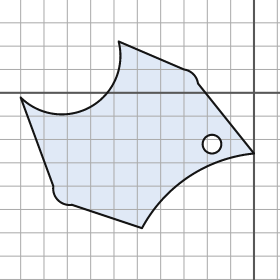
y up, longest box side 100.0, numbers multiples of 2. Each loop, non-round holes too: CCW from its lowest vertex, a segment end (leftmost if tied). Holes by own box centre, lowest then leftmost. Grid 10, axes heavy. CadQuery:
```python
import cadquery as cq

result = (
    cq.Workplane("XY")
    .moveTo(-48.0, -58.0)
    .threePointArc((-28.0, -36.0), (0.0, -26.0))
    .lineTo(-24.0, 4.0)
    .threePointArc((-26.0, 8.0), (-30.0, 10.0))
    .lineTo(-58.0, 22.0)
    .threePointArc((-70.0, -6.0), (-100.0, -2.0))
    .lineTo(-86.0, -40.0)
    .threePointArc((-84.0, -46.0), (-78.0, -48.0))
    .close()
    .moveTo(-18.0, -22.0)
    .circle(4.0)
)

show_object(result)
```